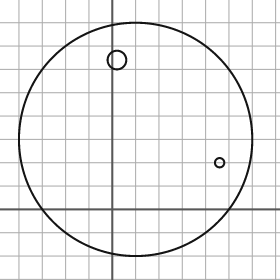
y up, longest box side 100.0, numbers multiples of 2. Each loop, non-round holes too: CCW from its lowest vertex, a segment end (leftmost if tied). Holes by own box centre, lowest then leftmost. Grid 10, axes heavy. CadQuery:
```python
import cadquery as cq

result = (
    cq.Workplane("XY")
    .moveTo(10.0, 30.0)
    .circle(50.0)
    .moveTo(46.0, 20.0)
    .circle(2.0)
    .moveTo(2.0, 64.0)
    .circle(4.0)
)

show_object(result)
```